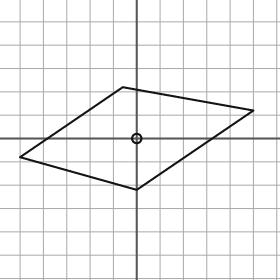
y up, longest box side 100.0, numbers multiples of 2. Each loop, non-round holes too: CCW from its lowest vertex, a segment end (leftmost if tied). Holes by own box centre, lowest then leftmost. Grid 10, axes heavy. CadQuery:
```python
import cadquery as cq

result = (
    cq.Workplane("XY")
    .moveTo(0.0, -22.0)
    .lineTo(50.0, 12.0)
    .lineTo(-6.0, 22.0)
    .lineTo(-50.0, -8.0)
    .close()
    .moveTo(0.0, 0.0)
    .circle(2.0)
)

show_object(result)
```